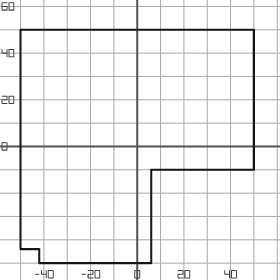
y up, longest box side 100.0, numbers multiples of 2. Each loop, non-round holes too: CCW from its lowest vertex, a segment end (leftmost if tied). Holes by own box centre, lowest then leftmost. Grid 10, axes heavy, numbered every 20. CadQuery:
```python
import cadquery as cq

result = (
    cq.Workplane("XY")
    .moveTo(-42.0, -50.0)
    .lineTo(6.0, -50.0)
    .lineTo(6.0, -10.0)
    .lineTo(50.0, -10.0)
    .lineTo(50.0, 50.0)
    .lineTo(-50.0, 50.0)
    .lineTo(-50.0, -44.0)
    .lineTo(-42.0, -44.0)
    .close()
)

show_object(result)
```